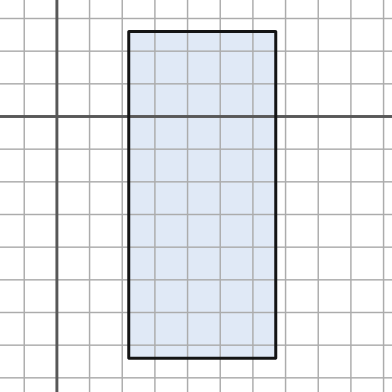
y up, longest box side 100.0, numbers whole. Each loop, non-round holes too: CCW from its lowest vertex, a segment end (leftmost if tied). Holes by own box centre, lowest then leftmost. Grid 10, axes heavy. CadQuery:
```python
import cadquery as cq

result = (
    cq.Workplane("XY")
    .moveTo(22.0, -74.0)
    .lineTo(67.0, -74.0)
    .lineTo(67.0, 26.0)
    .lineTo(22.0, 26.0)
    .close()
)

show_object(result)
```